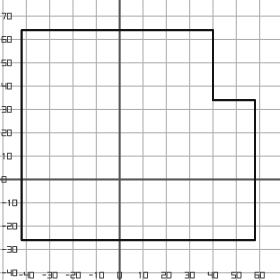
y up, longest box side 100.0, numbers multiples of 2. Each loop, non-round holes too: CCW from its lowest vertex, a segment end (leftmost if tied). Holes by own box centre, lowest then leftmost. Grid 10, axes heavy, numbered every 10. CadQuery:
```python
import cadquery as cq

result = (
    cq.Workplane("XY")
    .moveTo(-42.0, -26.0)
    .lineTo(58.0, -26.0)
    .lineTo(58.0, 34.0)
    .lineTo(40.0, 34.0)
    .lineTo(40.0, 64.0)
    .lineTo(-42.0, 64.0)
    .close()
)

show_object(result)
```